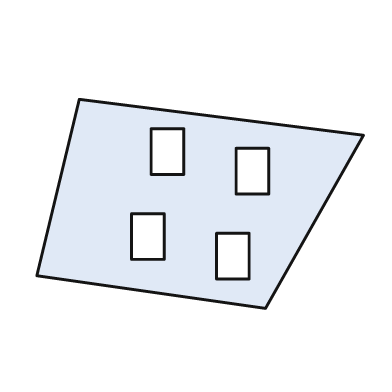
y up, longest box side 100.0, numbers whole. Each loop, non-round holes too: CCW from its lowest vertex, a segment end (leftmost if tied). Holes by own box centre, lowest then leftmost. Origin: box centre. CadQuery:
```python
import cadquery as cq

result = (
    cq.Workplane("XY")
    .moveTo(20.0, -32.0)
    .lineTo(50.0, 21.0)
    .lineTo(-37.0, 32.0)
    .lineTo(-50.0, -22.0)
    .close()
    .moveTo(5.0, -23.0)
    .lineTo(15.0, -23.0)
    .lineTo(15.0, -9.0)
    .lineTo(5.0, -9.0)
    .close()
    .moveTo(-21.0, -17.0)
    .lineTo(-11.0, -17.0)
    .lineTo(-11.0, -3.0)
    .lineTo(-21.0, -3.0)
    .close()
    .moveTo(11.0, 3.0)
    .lineTo(21.0, 3.0)
    .lineTo(21.0, 17.0)
    .lineTo(11.0, 17.0)
    .close()
    .moveTo(-15.0, 9.0)
    .lineTo(-5.0, 9.0)
    .lineTo(-5.0, 23.0)
    .lineTo(-15.0, 23.0)
    .close()
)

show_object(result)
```